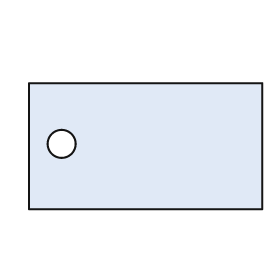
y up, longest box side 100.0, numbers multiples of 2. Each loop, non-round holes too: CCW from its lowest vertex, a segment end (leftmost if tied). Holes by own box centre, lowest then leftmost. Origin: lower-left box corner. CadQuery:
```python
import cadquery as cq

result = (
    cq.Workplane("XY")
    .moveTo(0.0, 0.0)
    .lineTo(100.0, 0.0)
    .lineTo(100.0, 54.0)
    .lineTo(0.0, 54.0)
    .close()
    .moveTo(14.0, 28.0)
    .circle(6.0)
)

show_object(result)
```